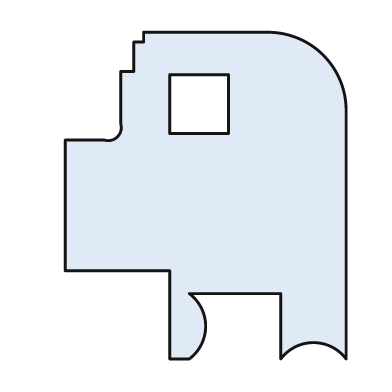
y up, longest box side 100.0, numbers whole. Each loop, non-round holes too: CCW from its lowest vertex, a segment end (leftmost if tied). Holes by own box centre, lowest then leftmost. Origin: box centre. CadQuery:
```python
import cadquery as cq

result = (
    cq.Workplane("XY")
    .moveTo(-11.0, -50.0)
    .lineTo(-5.0, -50.0)
    .threePointArc((0.0, -40.0), (-5.0, -30.0))
    .lineTo(23.0, -30.0)
    .lineTo(23.0, -50.0)
    .threePointArc((33.0, -45.0), (43.0, -50.0))
    .lineTo(43.0, 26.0)
    .threePointArc((36.0, 43.0), (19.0, 50.0))
    .lineTo(-19.0, 50.0)
    .lineTo(-19.0, 47.0)
    .lineTo(-22.0, 47.0)
    .lineTo(-22.0, 38.0)
    .lineTo(-26.0, 38.0)
    .lineTo(-26.0, 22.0)
    .threePointArc((-27.0, 18.0), (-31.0, 17.0))
    .lineTo(-43.0, 17.0)
    .lineTo(-43.0, -23.0)
    .lineTo(-11.0, -23.0)
    .close()
    .moveTo(-11.0, 19.0)
    .lineTo(7.0, 19.0)
    .lineTo(7.0, 37.0)
    .lineTo(-11.0, 37.0)
    .close()
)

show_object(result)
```